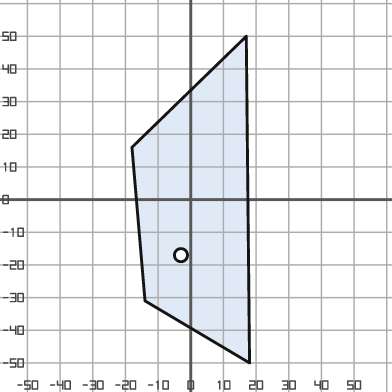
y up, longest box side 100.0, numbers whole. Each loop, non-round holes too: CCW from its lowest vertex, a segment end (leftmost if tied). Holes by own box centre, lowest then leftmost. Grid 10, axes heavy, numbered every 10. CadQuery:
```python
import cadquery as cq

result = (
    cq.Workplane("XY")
    .moveTo(18.0, -50.0)
    .lineTo(17.0, 50.0)
    .lineTo(-18.0, 16.0)
    .lineTo(-14.0, -31.0)
    .close()
    .moveTo(-3.0, -17.0)
    .circle(2.0)
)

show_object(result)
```